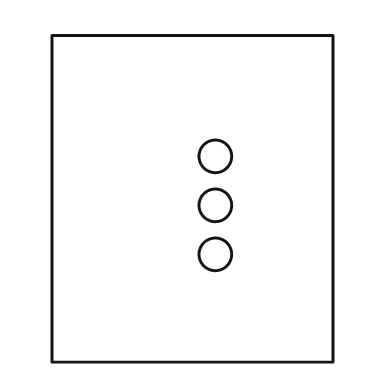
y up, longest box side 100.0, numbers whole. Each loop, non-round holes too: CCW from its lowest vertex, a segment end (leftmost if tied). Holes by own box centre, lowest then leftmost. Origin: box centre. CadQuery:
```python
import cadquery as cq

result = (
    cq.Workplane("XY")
    .moveTo(-43.0, -50.0)
    .lineTo(43.0, -50.0)
    .lineTo(43.0, 50.0)
    .lineTo(-43.0, 50.0)
    .close()
    .moveTo(7.0, -17.0)
    .circle(5.0)
    .moveTo(7.0, -2.0)
    .circle(5.0)
    .moveTo(7.0, 13.0)
    .circle(5.0)
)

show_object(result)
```